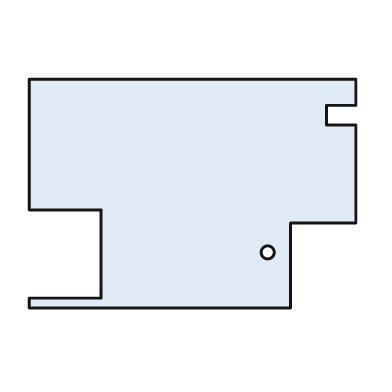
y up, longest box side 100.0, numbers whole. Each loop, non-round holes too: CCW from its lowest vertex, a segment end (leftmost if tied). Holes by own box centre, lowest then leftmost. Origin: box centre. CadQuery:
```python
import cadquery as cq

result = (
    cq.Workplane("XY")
    .moveTo(-50.0, -35.0)
    .lineTo(30.0, -35.0)
    .lineTo(30.0, -9.0)
    .lineTo(50.0, -9.0)
    .lineTo(50.0, 21.0)
    .lineTo(41.0, 21.0)
    .lineTo(41.0, 27.0)
    .lineTo(50.0, 27.0)
    .lineTo(50.0, 35.0)
    .lineTo(-50.0, 35.0)
    .lineTo(-50.0, -5.0)
    .lineTo(-28.0, -5.0)
    .lineTo(-28.0, -32.0)
    .lineTo(-50.0, -32.0)
    .close()
    .moveTo(23.0, -18.0)
    .circle(2.0)
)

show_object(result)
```